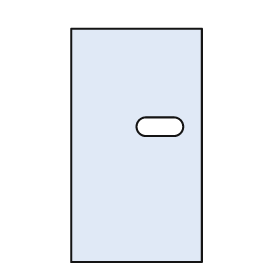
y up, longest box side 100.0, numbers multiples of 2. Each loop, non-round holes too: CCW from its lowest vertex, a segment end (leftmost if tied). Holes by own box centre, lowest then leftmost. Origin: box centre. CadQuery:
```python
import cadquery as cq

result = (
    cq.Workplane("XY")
    .moveTo(-28.0, -50.0)
    .lineTo(28.0, -50.0)
    .lineTo(28.0, 50.0)
    .lineTo(-28.0, 50.0)
    .close()
    .moveTo(4.0, 4.0)
    .lineTo(16.0, 4.0)
    .threePointArc((20.0, 8.0), (16.0, 12.0))
    .lineTo(4.0, 12.0)
    .threePointArc((0.0, 8.0), (4.0, 4.0))
    .close()
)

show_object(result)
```